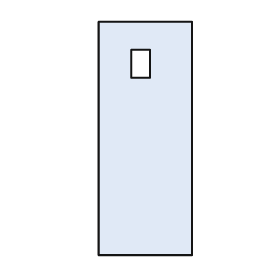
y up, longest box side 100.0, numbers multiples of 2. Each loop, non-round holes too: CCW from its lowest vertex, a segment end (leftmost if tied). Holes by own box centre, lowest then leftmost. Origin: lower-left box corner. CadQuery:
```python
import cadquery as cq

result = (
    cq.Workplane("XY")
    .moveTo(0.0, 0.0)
    .lineTo(40.0, 0.0)
    .lineTo(40.0, 100.0)
    .lineTo(0.0, 100.0)
    .close()
    .moveTo(14.0, 76.0)
    .lineTo(22.0, 76.0)
    .lineTo(22.0, 88.0)
    .lineTo(14.0, 88.0)
    .close()
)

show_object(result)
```